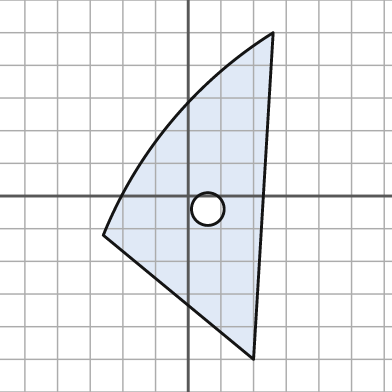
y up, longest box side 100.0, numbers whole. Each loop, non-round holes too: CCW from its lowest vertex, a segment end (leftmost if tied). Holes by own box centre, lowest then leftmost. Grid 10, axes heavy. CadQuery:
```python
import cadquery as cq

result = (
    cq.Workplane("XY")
    .moveTo(20.0, -50.0)
    .lineTo(26.0, 50.0)
    .threePointArc((-5.0, 23.0), (-26.0, -12.0))
    .close()
    .moveTo(6.0, -4.0)
    .circle(5.0)
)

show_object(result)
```